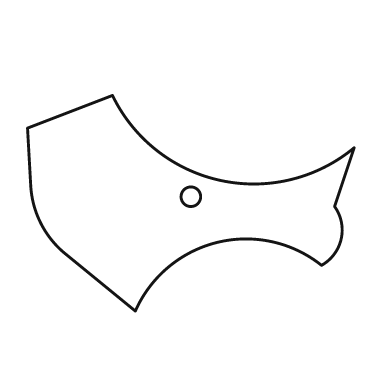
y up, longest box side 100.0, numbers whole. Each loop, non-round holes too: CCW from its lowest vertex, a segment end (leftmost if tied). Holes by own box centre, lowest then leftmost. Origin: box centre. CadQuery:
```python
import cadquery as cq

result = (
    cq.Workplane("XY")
    .moveTo(-17.0, -33.0)
    .threePointArc((8.0, -12.0), (40.0, -19.0))
    .threePointArc((46.0, -11.0), (44.0, -1.0))
    .lineTo(50.0, 17.0)
    .threePointArc((9.0, 7.0), (-24.0, 33.0))
    .lineTo(-50.0, 23.0)
    .lineTo(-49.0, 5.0)
    .threePointArc((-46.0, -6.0), (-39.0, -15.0))
    .close()
    .moveTo(0.0, 2.0)
    .circle(3.0)
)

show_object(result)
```